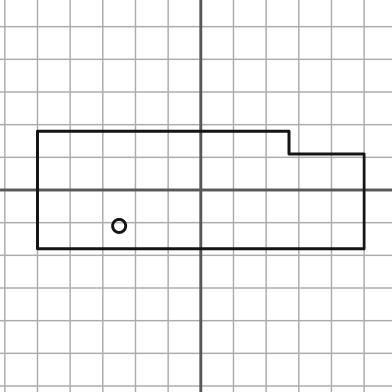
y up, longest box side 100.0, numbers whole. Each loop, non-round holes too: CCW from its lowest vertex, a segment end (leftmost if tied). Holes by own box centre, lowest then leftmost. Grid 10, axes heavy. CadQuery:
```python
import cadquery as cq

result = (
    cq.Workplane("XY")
    .moveTo(-50.0, -18.0)
    .lineTo(50.0, -18.0)
    .lineTo(50.0, 11.0)
    .lineTo(27.0, 11.0)
    .lineTo(27.0, 18.0)
    .lineTo(-50.0, 18.0)
    .close()
    .moveTo(-25.0, -11.0)
    .circle(2.0)
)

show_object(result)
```